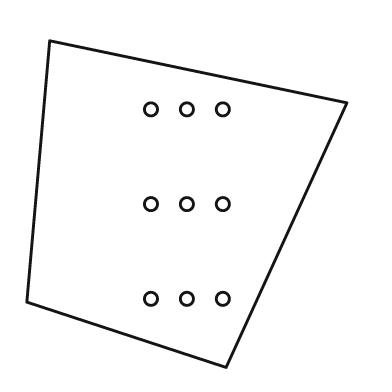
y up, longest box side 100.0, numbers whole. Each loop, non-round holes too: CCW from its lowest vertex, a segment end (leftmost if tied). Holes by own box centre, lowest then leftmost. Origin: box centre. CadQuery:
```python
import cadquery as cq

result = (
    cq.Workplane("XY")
    .moveTo(12.0, -50.0)
    .lineTo(49.0, 31.0)
    .lineTo(-42.0, 50.0)
    .lineTo(-49.0, -30.0)
    .close()
    .moveTo(-11.0, -29.0)
    .circle(2.0)
    .moveTo(0.0, -29.0)
    .circle(2.0)
    .moveTo(11.0, -29.0)
    .circle(2.0)
    .moveTo(-11.0, 0.0)
    .circle(2.0)
    .moveTo(0.0, 0.0)
    .circle(2.0)
    .moveTo(11.0, 0.0)
    .circle(2.0)
    .moveTo(-11.0, 29.0)
    .circle(2.0)
    .moveTo(0.0, 29.0)
    .circle(2.0)
    .moveTo(11.0, 29.0)
    .circle(2.0)
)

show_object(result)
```